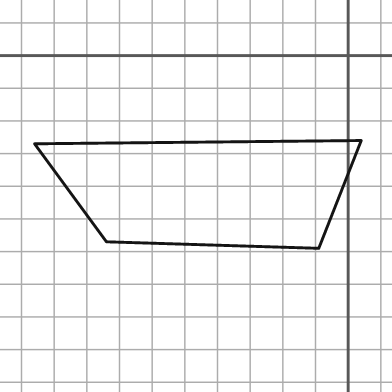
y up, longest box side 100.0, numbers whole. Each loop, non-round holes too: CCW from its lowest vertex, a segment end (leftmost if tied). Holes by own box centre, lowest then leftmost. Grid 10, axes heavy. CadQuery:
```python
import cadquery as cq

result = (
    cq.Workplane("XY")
    .moveTo(-9.0, -59.0)
    .lineTo(4.0, -26.0)
    .lineTo(-96.0, -27.0)
    .lineTo(-74.0, -57.0)
    .close()
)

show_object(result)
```